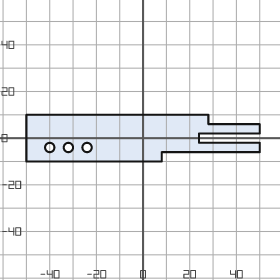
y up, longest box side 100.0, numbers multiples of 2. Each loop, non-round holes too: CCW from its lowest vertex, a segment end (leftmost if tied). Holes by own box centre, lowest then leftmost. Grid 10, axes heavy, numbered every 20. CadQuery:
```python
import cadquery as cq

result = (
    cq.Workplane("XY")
    .moveTo(-50.0, -10.0)
    .lineTo(8.0, -10.0)
    .lineTo(8.0, -6.0)
    .lineTo(50.0, -6.0)
    .lineTo(50.0, -2.0)
    .lineTo(24.0, -2.0)
    .lineTo(24.0, 2.0)
    .lineTo(50.0, 2.0)
    .lineTo(50.0, 6.0)
    .lineTo(28.0, 6.0)
    .lineTo(28.0, 10.0)
    .lineTo(-50.0, 10.0)
    .close()
    .moveTo(-40.0, -4.0)
    .circle(2.0)
    .moveTo(-32.0, -4.0)
    .circle(2.0)
    .moveTo(-24.0, -4.0)
    .circle(2.0)
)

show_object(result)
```